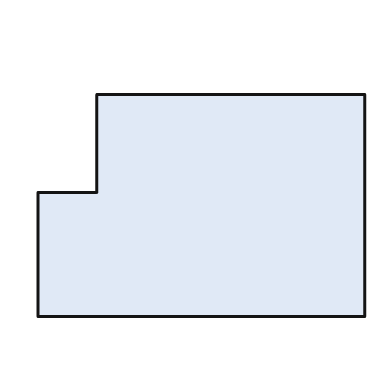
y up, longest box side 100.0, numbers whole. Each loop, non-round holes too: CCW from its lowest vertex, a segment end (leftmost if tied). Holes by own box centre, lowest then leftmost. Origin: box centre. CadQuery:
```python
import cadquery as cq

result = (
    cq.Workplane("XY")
    .moveTo(-50.0, -34.0)
    .lineTo(50.0, -34.0)
    .lineTo(50.0, 34.0)
    .lineTo(-32.0, 34.0)
    .lineTo(-32.0, 4.0)
    .lineTo(-50.0, 4.0)
    .close()
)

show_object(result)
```